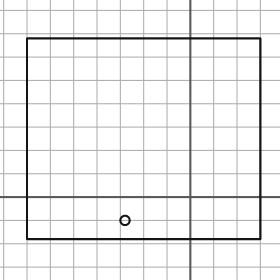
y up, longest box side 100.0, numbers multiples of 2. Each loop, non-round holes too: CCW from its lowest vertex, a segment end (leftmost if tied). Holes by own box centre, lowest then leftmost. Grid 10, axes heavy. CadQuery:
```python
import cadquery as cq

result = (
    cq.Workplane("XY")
    .moveTo(-70.0, -18.0)
    .lineTo(30.0, -18.0)
    .lineTo(30.0, 68.0)
    .lineTo(-70.0, 68.0)
    .close()
    .moveTo(-28.0, -10.0)
    .circle(2.0)
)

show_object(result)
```